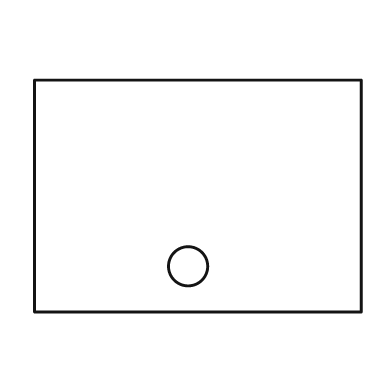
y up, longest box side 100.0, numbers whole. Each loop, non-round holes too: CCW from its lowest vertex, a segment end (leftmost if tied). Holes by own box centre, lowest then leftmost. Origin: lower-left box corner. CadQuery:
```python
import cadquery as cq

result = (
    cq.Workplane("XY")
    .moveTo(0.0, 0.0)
    .lineTo(100.0, 0.0)
    .lineTo(100.0, 71.0)
    .lineTo(0.0, 71.0)
    .close()
    .moveTo(47.0, 14.0)
    .circle(6.0)
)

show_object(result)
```